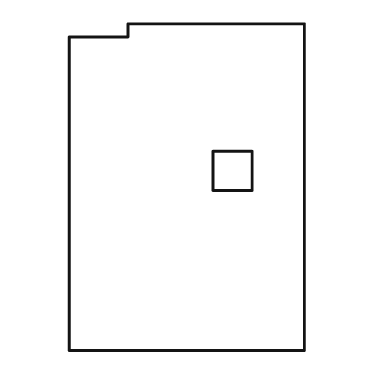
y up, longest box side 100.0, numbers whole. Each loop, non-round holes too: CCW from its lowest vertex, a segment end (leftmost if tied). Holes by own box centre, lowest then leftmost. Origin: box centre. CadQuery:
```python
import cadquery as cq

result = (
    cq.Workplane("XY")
    .moveTo(-36.0, -50.0)
    .lineTo(36.0, -50.0)
    .lineTo(36.0, 50.0)
    .lineTo(-18.0, 50.0)
    .lineTo(-18.0, 46.0)
    .lineTo(-36.0, 46.0)
    .close()
    .moveTo(8.0, -1.0)
    .lineTo(20.0, -1.0)
    .lineTo(20.0, 11.0)
    .lineTo(8.0, 11.0)
    .close()
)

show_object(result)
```